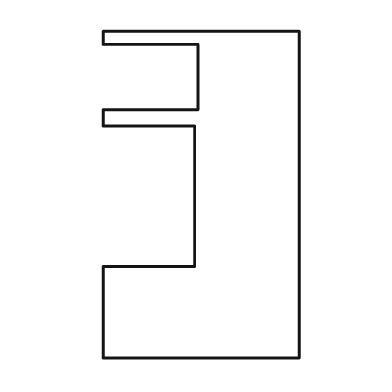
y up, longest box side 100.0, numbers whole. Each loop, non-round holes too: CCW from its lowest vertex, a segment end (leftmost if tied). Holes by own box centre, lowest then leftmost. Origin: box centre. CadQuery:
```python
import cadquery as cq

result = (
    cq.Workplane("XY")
    .moveTo(-30.0, -50.0)
    .lineTo(30.0, -50.0)
    .lineTo(30.0, 50.0)
    .lineTo(-30.0, 50.0)
    .lineTo(-30.0, 46.0)
    .lineTo(-1.0, 46.0)
    .lineTo(-1.0, 26.0)
    .lineTo(-30.0, 26.0)
    .lineTo(-30.0, 21.0)
    .lineTo(-2.0, 21.0)
    .lineTo(-2.0, -22.0)
    .lineTo(-30.0, -22.0)
    .close()
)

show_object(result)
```